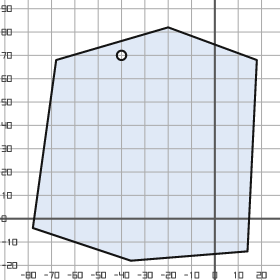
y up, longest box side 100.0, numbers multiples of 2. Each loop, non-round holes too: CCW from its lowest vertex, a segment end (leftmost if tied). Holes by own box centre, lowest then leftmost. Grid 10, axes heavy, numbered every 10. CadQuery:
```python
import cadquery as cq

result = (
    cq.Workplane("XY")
    .moveTo(-36.0, -18.0)
    .lineTo(14.0, -14.0)
    .lineTo(18.0, 68.0)
    .lineTo(-20.0, 82.0)
    .lineTo(-68.0, 68.0)
    .lineTo(-78.0, -4.0)
    .close()
    .moveTo(-40.0, 70.0)
    .circle(2.0)
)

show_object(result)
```